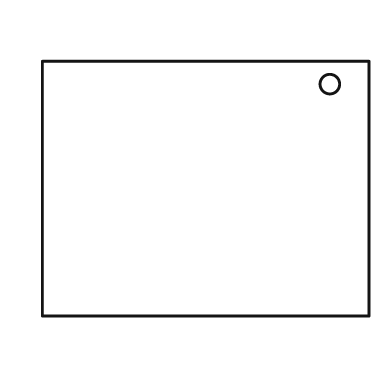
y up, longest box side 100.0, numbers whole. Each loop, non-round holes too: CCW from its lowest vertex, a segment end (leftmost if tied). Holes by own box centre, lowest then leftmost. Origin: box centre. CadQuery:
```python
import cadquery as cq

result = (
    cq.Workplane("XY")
    .moveTo(-50.0, -39.0)
    .lineTo(50.0, -39.0)
    .lineTo(50.0, 39.0)
    .lineTo(-50.0, 39.0)
    .close()
    .moveTo(38.0, 32.0)
    .circle(3.0)
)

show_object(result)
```